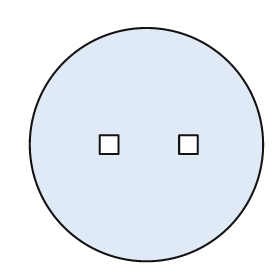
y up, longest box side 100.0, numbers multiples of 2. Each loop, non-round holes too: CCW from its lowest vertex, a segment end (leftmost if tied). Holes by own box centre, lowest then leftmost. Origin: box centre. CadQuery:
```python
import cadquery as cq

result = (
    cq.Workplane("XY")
    .moveTo(0.0, 0.0)
    .circle(50.0)
    .moveTo(-20.0, -4.0)
    .lineTo(-12.0, -4.0)
    .lineTo(-12.0, 4.0)
    .lineTo(-20.0, 4.0)
    .close()
    .moveTo(14.0, -4.0)
    .lineTo(22.0, -4.0)
    .lineTo(22.0, 4.0)
    .lineTo(14.0, 4.0)
    .close()
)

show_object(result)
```